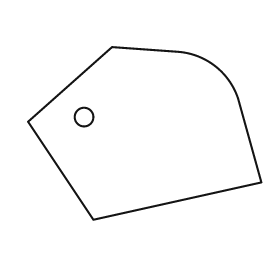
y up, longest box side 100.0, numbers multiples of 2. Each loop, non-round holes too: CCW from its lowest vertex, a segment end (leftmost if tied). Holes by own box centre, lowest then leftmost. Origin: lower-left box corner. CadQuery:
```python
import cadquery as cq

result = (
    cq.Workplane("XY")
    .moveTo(28.0, 0.0)
    .lineTo(100.0, 16.0)
    .lineTo(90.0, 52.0)
    .threePointArc((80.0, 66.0), (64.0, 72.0))
    .lineTo(36.0, 74.0)
    .lineTo(0.0, 42.0)
    .close()
    .moveTo(24.0, 44.0)
    .circle(4.0)
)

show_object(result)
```